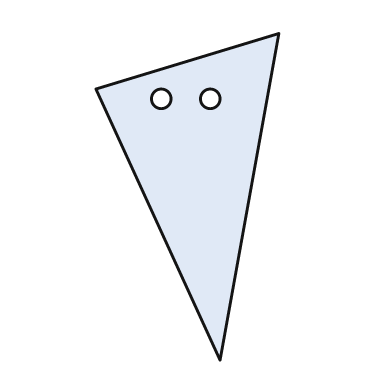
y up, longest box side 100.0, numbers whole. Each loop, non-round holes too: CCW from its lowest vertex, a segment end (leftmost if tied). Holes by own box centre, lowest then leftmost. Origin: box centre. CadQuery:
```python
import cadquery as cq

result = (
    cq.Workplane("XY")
    .moveTo(10.0, -50.0)
    .lineTo(28.0, 50.0)
    .lineTo(-28.0, 33.0)
    .close()
    .moveTo(-8.0, 30.0)
    .circle(3.0)
    .moveTo(7.0, 30.0)
    .circle(3.0)
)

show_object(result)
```